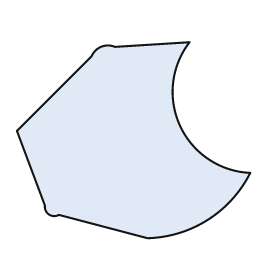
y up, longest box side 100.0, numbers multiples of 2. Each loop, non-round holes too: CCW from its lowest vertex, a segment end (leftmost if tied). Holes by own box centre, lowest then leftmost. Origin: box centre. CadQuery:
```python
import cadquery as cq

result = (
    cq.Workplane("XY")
    .moveTo(6.0, -42.0)
    .threePointArc((32.0, -34.0), (50.0, -14.0))
    .threePointArc((20.0, 6.0), (24.0, 42.0))
    .lineTo(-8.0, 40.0)
    .threePointArc((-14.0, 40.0), (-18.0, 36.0))
    .lineTo(-50.0, 4.0)
    .lineTo(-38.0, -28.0)
    .threePointArc((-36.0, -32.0), (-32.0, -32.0))
    .close()
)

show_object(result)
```